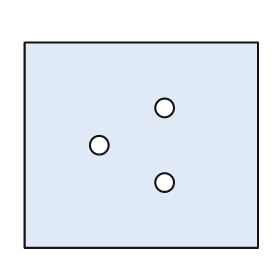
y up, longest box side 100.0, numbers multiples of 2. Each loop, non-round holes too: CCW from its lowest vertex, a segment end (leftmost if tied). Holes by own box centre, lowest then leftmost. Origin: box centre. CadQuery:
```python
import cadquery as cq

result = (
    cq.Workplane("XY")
    .moveTo(-50.0, -44.0)
    .lineTo(50.0, -44.0)
    .lineTo(50.0, 44.0)
    .lineTo(-50.0, 44.0)
    .close()
    .moveTo(10.0, -16.0)
    .circle(4.0)
    .moveTo(-18.0, 0.0)
    .circle(4.0)
    .moveTo(10.0, 16.0)
    .circle(4.0)
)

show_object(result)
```